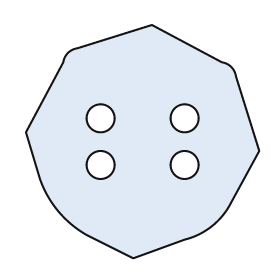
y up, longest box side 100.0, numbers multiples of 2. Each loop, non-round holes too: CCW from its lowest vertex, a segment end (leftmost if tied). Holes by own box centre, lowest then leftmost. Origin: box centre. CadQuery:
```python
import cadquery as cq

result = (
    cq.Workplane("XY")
    .moveTo(-4.0, -50.0)
    .lineTo(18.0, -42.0)
    .threePointArc((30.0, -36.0), (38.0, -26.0))
    .lineTo(50.0, -4.0)
    .lineTo(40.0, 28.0)
    .threePointArc((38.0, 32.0), (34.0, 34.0))
    .lineTo(4.0, 50.0)
    .lineTo(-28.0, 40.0)
    .threePointArc((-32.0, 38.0), (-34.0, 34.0))
    .lineTo(-50.0, 4.0)
    .lineTo(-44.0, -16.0)
    .threePointArc((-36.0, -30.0), (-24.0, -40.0))
    .close()
    .moveTo(-18.0, -10.0)
    .circle(6.0)
    .moveTo(18.0, -10.0)
    .circle(6.0)
    .moveTo(-18.0, 10.0)
    .circle(6.0)
    .moveTo(18.0, 10.0)
    .circle(6.0)
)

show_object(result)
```